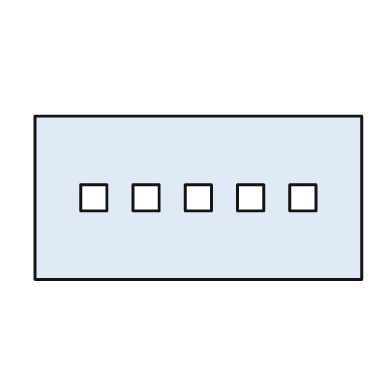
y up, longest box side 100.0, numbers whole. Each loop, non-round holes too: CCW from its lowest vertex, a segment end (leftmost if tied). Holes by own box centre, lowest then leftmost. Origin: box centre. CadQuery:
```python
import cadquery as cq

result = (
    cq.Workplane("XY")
    .moveTo(-50.0, -25.0)
    .lineTo(50.0, -25.0)
    .lineTo(50.0, 25.0)
    .lineTo(-50.0, 25.0)
    .close()
    .moveTo(-36.0, -4.0)
    .lineTo(-28.0, -4.0)
    .lineTo(-28.0, 4.0)
    .lineTo(-36.0, 4.0)
    .close()
    .moveTo(-20.0, -4.0)
    .lineTo(-12.0, -4.0)
    .lineTo(-12.0, 4.0)
    .lineTo(-20.0, 4.0)
    .close()
    .moveTo(-4.0, -4.0)
    .lineTo(4.0, -4.0)
    .lineTo(4.0, 4.0)
    .lineTo(-4.0, 4.0)
    .close()
    .moveTo(12.0, -4.0)
    .lineTo(20.0, -4.0)
    .lineTo(20.0, 4.0)
    .lineTo(12.0, 4.0)
    .close()
    .moveTo(28.0, -4.0)
    .lineTo(36.0, -4.0)
    .lineTo(36.0, 4.0)
    .lineTo(28.0, 4.0)
    .close()
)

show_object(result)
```